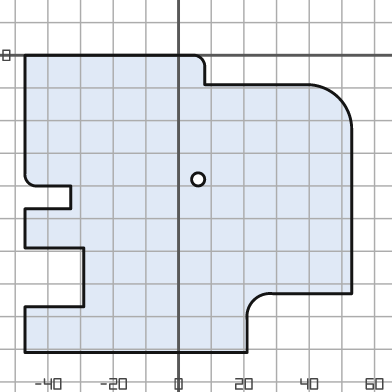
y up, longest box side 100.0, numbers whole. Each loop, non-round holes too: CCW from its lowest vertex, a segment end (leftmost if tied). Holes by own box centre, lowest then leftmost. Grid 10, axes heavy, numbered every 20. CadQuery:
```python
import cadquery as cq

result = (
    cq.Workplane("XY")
    .moveTo(-47.0, -91.0)
    .lineTo(21.0, -91.0)
    .lineTo(21.0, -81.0)
    .threePointArc((23.0, -75.0), (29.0, -73.0))
    .lineTo(53.0, -73.0)
    .lineTo(53.0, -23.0)
    .threePointArc((49.0, -13.0), (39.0, -9.0))
    .lineTo(8.0, -9.0)
    .lineTo(8.0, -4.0)
    .threePointArc((7.0, -1.0), (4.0, 0.0))
    .lineTo(-47.0, 0.0)
    .lineTo(-47.0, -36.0)
    .threePointArc((-46.0, -39.0), (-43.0, -40.0))
    .lineTo(-33.0, -40.0)
    .lineTo(-33.0, -47.0)
    .lineTo(-47.0, -47.0)
    .lineTo(-47.0, -59.0)
    .lineTo(-29.0, -59.0)
    .lineTo(-29.0, -77.0)
    .lineTo(-47.0, -77.0)
    .close()
    .moveTo(6.0, -38.0)
    .circle(2.0)
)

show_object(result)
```